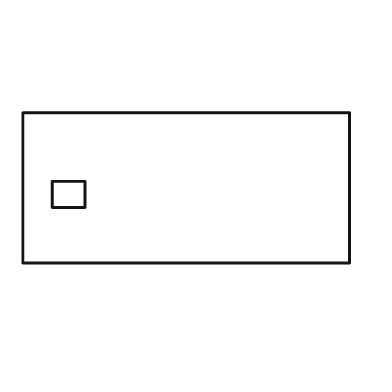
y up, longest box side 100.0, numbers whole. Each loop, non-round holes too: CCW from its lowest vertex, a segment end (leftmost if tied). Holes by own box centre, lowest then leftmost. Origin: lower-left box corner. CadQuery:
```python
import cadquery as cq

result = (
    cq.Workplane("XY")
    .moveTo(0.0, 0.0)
    .lineTo(100.0, 0.0)
    .lineTo(100.0, 46.0)
    .lineTo(0.0, 46.0)
    .close()
    .moveTo(9.0, 17.0)
    .lineTo(19.0, 17.0)
    .lineTo(19.0, 25.0)
    .lineTo(9.0, 25.0)
    .close()
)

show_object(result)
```